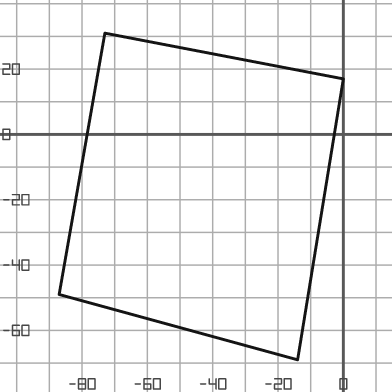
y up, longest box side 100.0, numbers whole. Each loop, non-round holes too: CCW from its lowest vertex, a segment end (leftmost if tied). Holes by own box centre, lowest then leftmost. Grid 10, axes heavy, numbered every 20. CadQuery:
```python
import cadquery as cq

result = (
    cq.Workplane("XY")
    .moveTo(-14.0, -69.0)
    .lineTo(0.0, 17.0)
    .lineTo(-73.0, 31.0)
    .lineTo(-87.0, -49.0)
    .close()
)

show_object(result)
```